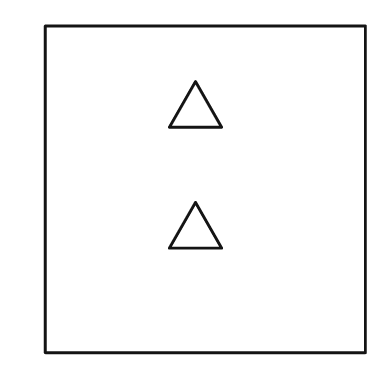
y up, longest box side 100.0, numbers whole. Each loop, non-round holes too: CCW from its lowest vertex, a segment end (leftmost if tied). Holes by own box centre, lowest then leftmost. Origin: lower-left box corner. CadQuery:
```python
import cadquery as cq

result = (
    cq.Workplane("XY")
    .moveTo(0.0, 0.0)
    .lineTo(98.0, 0.0)
    .lineTo(98.0, 100.0)
    .lineTo(0.0, 100.0)
    .close()
    .moveTo(38.0, 32.0)
    .lineTo(54.0, 32.0)
    .lineTo(46.0, 46.0)
    .close()
    .moveTo(38.0, 69.0)
    .lineTo(54.0, 69.0)
    .lineTo(46.0, 83.0)
    .close()
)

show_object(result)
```